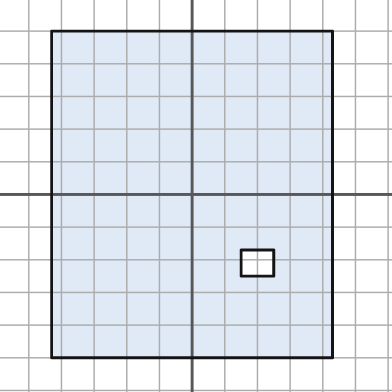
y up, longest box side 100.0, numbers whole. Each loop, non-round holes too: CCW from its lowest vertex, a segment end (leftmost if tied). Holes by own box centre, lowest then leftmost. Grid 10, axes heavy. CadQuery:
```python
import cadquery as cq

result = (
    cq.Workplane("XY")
    .moveTo(-43.0, -50.0)
    .lineTo(43.0, -50.0)
    .lineTo(43.0, 50.0)
    .lineTo(-43.0, 50.0)
    .close()
    .moveTo(15.0, -25.0)
    .lineTo(25.0, -25.0)
    .lineTo(25.0, -17.0)
    .lineTo(15.0, -17.0)
    .close()
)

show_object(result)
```